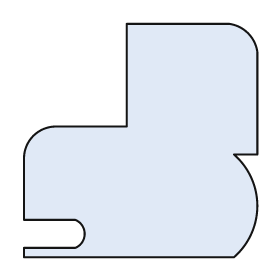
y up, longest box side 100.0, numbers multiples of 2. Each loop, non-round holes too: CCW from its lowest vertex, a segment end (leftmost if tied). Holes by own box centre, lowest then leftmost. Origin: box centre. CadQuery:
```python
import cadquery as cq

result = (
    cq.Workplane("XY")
    .moveTo(-50.0, -50.0)
    .lineTo(40.0, -50.0)
    .threePointArc((50.0, -28.0), (40.0, -6.0))
    .lineTo(50.0, -6.0)
    .lineTo(50.0, 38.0)
    .threePointArc((46.0, 46.0), (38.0, 50.0))
    .lineTo(-6.0, 50.0)
    .lineTo(-6.0, 6.0)
    .lineTo(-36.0, 6.0)
    .threePointArc((-46.0, 2.0), (-50.0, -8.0))
    .lineTo(-50.0, -34.0)
    .lineTo(-28.0, -34.0)
    .threePointArc((-24.0, -40.0), (-28.0, -46.0))
    .lineTo(-50.0, -46.0)
    .close()
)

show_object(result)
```